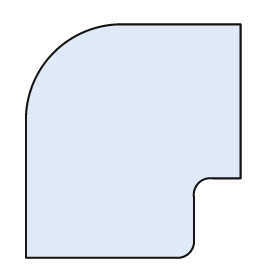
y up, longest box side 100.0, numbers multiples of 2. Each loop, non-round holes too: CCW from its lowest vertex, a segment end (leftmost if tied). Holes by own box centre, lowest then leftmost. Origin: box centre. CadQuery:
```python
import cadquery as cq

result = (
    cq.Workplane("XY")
    .moveTo(-46.0, -50.0)
    .lineTo(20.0, -50.0)
    .threePointArc((24.0, -48.0), (26.0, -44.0))
    .lineTo(26.0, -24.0)
    .threePointArc((28.0, -18.0), (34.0, -16.0))
    .lineTo(46.0, -16.0)
    .lineTo(46.0, 50.0)
    .lineTo(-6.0, 50.0)
    .threePointArc((-34.0, 38.0), (-46.0, 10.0))
    .close()
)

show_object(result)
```